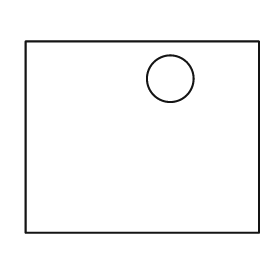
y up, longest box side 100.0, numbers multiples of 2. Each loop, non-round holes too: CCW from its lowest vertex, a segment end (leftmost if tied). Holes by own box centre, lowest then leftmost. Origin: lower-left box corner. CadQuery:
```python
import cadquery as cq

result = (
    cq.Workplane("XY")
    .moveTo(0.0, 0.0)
    .lineTo(100.0, 0.0)
    .lineTo(100.0, 82.0)
    .lineTo(0.0, 82.0)
    .close()
    .moveTo(62.0, 66.0)
    .circle(10.0)
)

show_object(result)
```